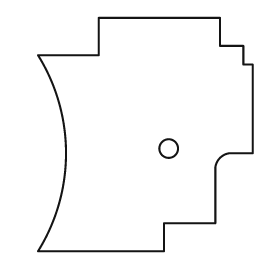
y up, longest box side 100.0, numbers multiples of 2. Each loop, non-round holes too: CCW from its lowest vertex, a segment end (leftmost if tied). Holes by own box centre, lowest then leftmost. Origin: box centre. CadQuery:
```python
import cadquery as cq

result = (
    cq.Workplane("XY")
    .moveTo(-46.0, -50.0)
    .lineTo(8.0, -50.0)
    .lineTo(8.0, -38.0)
    .lineTo(30.0, -38.0)
    .lineTo(30.0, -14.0)
    .threePointArc((32.0, -10.0), (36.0, -8.0))
    .lineTo(46.0, -8.0)
    .lineTo(46.0, 30.0)
    .lineTo(42.0, 30.0)
    .lineTo(42.0, 38.0)
    .lineTo(32.0, 38.0)
    .lineTo(32.0, 50.0)
    .lineTo(-20.0, 50.0)
    .lineTo(-20.0, 34.0)
    .lineTo(-46.0, 34.0)
    .threePointArc((-34.0, -8.0), (-46.0, -50.0))
    .close()
    .moveTo(10.0, -6.0)
    .circle(4.0)
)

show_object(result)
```